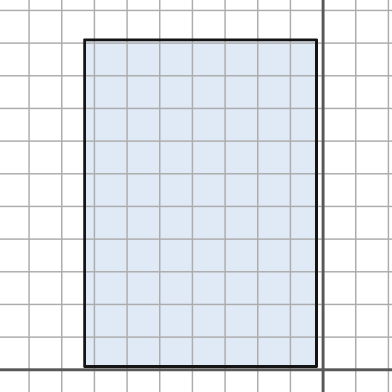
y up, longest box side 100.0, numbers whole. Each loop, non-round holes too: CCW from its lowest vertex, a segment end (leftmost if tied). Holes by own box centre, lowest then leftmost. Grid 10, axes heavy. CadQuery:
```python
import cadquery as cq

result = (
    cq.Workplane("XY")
    .moveTo(-73.0, 1.0)
    .lineTo(-2.0, 1.0)
    .lineTo(-2.0, 101.0)
    .lineTo(-73.0, 101.0)
    .close()
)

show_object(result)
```